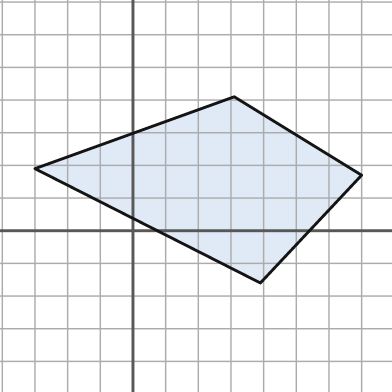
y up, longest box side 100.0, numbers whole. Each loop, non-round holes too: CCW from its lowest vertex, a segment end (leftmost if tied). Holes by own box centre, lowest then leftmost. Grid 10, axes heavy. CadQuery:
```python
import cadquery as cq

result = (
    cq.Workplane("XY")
    .moveTo(39.0, -16.0)
    .lineTo(70.0, 17.0)
    .lineTo(31.0, 41.0)
    .lineTo(-30.0, 19.0)
    .close()
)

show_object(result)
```